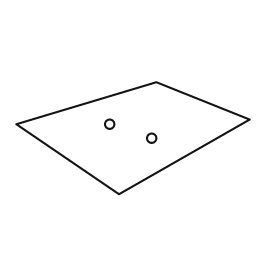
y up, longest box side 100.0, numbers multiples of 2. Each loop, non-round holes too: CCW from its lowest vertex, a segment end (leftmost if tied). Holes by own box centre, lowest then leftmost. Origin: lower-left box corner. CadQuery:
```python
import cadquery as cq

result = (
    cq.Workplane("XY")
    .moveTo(44.0, 0.0)
    .lineTo(100.0, 32.0)
    .lineTo(60.0, 48.0)
    .lineTo(0.0, 30.0)
    .close()
    .moveTo(58.0, 24.0)
    .circle(2.0)
    .moveTo(40.0, 30.0)
    .circle(2.0)
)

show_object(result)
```